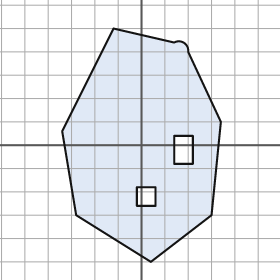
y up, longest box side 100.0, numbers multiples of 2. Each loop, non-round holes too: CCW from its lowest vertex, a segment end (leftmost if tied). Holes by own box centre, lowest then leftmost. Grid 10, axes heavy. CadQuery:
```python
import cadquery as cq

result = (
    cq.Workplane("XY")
    .moveTo(4.0, -50.0)
    .lineTo(30.0, -30.0)
    .lineTo(34.0, 10.0)
    .lineTo(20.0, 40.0)
    .threePointArc((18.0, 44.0), (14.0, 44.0))
    .lineTo(-12.0, 50.0)
    .lineTo(-34.0, 6.0)
    .lineTo(-28.0, -30.0)
    .close()
    .moveTo(-2.0, -26.0)
    .lineTo(6.0, -26.0)
    .lineTo(6.0, -18.0)
    .lineTo(-2.0, -18.0)
    .close()
    .moveTo(14.0, -8.0)
    .lineTo(22.0, -8.0)
    .lineTo(22.0, 4.0)
    .lineTo(14.0, 4.0)
    .close()
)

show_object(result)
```